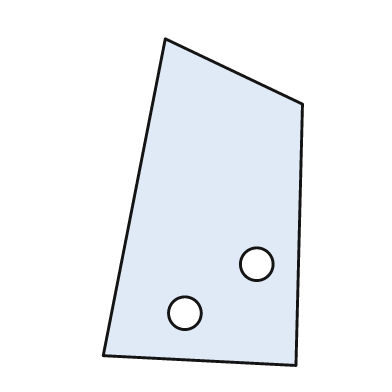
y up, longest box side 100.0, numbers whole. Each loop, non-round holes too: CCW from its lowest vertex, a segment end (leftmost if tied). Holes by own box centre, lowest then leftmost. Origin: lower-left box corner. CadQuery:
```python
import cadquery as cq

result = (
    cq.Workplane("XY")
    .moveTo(59.0, 0.0)
    .lineTo(61.0, 80.0)
    .lineTo(19.0, 100.0)
    .lineTo(0.0, 3.0)
    .close()
    .moveTo(25.0, 16.0)
    .circle(5.0)
    .moveTo(47.0, 31.0)
    .circle(5.0)
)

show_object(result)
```